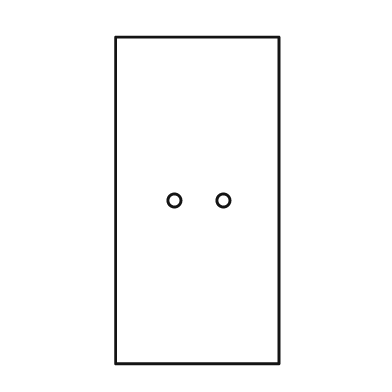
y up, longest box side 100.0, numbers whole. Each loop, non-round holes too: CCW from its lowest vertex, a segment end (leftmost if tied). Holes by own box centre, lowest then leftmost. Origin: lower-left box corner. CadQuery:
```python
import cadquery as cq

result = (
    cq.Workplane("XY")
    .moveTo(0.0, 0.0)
    .lineTo(50.0, 0.0)
    .lineTo(50.0, 100.0)
    .lineTo(0.0, 100.0)
    .close()
    .moveTo(18.0, 50.0)
    .circle(2.0)
    .moveTo(33.0, 50.0)
    .circle(2.0)
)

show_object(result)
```